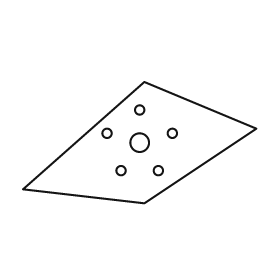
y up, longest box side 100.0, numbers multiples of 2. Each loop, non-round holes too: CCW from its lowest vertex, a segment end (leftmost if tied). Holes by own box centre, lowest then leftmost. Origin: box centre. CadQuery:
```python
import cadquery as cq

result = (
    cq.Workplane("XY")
    .moveTo(2.0, -26.0)
    .lineTo(50.0, 6.0)
    .lineTo(2.0, 26.0)
    .lineTo(-50.0, -20.0)
    .close()
    .moveTo(-8.0, -12.0)
    .circle(2.0)
    .moveTo(8.0, -12.0)
    .circle(2.0)
    .moveTo(0.0, 0.0)
    .circle(4.0)
    .moveTo(-14.0, 4.0)
    .circle(2.0)
    .moveTo(14.0, 4.0)
    .circle(2.0)
    .moveTo(0.0, 14.0)
    .circle(2.0)
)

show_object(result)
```